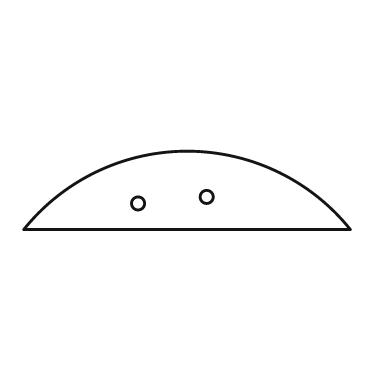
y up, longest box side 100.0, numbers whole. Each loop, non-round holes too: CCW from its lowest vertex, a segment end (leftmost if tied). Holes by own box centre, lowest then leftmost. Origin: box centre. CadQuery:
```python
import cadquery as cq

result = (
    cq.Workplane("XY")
    .moveTo(-50.0, -12.0)
    .lineTo(50.0, -12.0)
    .threePointArc((0.0, 12.0), (-50.0, -12.0))
    .close()
    .moveTo(-15.0, -4.0)
    .circle(2.0)
    .moveTo(6.0, -2.0)
    .circle(2.0)
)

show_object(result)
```